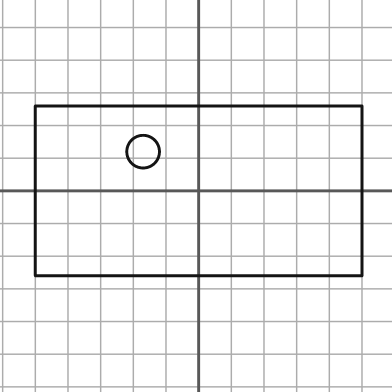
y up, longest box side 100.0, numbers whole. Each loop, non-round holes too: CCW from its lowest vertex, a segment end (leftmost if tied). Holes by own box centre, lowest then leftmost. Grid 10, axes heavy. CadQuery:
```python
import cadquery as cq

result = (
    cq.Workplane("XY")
    .moveTo(-50.0, -26.0)
    .lineTo(50.0, -26.0)
    .lineTo(50.0, 26.0)
    .lineTo(-50.0, 26.0)
    .close()
    .moveTo(-17.0, 12.0)
    .circle(5.0)
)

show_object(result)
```